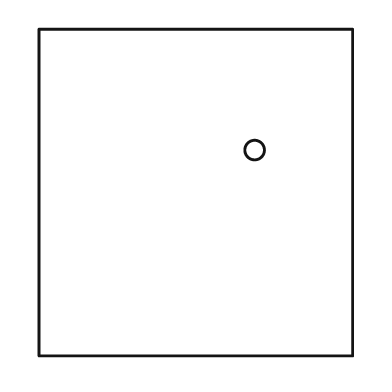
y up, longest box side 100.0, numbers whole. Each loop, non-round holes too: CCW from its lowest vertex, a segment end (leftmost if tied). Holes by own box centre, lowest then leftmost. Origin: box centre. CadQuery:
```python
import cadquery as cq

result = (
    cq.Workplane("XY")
    .moveTo(-48.0, -50.0)
    .lineTo(48.0, -50.0)
    .lineTo(48.0, 50.0)
    .lineTo(-48.0, 50.0)
    .close()
    .moveTo(18.0, 13.0)
    .circle(3.0)
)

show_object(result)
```